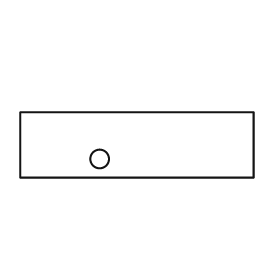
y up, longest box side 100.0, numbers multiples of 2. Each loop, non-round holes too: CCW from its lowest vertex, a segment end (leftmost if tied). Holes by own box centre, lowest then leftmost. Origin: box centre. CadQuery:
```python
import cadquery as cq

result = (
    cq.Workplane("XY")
    .moveTo(-50.0, -14.0)
    .lineTo(50.0, -14.0)
    .lineTo(50.0, 14.0)
    .lineTo(-50.0, 14.0)
    .close()
    .moveTo(-16.0, -6.0)
    .circle(4.0)
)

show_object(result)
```